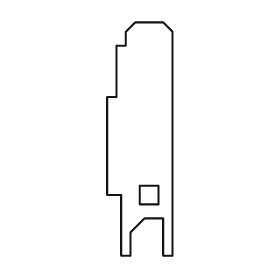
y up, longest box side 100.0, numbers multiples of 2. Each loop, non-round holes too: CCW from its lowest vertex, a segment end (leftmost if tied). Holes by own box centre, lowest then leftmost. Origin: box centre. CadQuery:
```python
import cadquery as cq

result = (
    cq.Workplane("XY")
    .moveTo(-8.0, -50.0)
    .lineTo(-4.0, -50.0)
    .lineTo(-4.0, -40.0)
    .lineTo(2.0, -34.0)
    .lineTo(10.0, -34.0)
    .lineTo(10.0, -50.0)
    .lineTo(14.0, -50.0)
    .lineTo(14.0, 46.0)
    .lineTo(10.0, 50.0)
    .lineTo(-2.0, 50.0)
    .lineTo(-6.0, 46.0)
    .lineTo(-6.0, 40.0)
    .lineTo(-10.0, 40.0)
    .lineTo(-10.0, 18.0)
    .lineTo(-14.0, 18.0)
    .lineTo(-14.0, -24.0)
    .lineTo(-8.0, -24.0)
    .close()
    .moveTo(0.0, -28.0)
    .lineTo(8.0, -28.0)
    .lineTo(8.0, -20.0)
    .lineTo(0.0, -20.0)
    .close()
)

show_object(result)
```